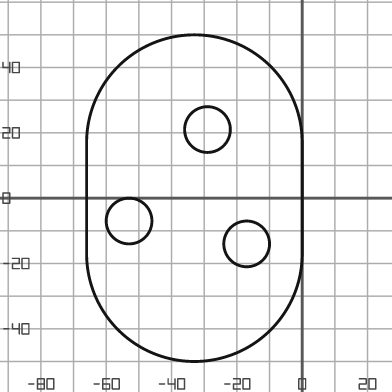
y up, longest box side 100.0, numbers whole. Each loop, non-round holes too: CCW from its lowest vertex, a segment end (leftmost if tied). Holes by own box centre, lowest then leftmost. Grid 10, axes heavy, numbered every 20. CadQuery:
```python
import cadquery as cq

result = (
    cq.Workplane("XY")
    .moveTo(-66.0, -17.0)
    .threePointArc((-33.0, -50.0), (0.0, -17.0))
    .lineTo(0.0, 17.0)
    .threePointArc((-33.0, 50.0), (-66.0, 17.0))
    .close()
    .moveTo(-17.0, -14.0)
    .circle(7.0)
    .moveTo(-53.0, -7.0)
    .circle(7.0)
    .moveTo(-29.0, 21.0)
    .circle(7.0)
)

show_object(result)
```